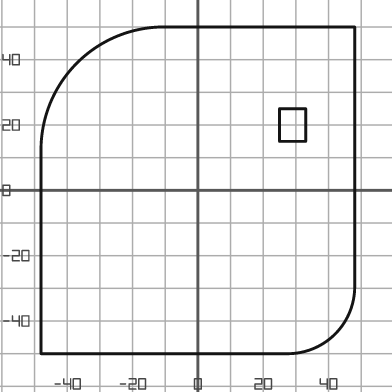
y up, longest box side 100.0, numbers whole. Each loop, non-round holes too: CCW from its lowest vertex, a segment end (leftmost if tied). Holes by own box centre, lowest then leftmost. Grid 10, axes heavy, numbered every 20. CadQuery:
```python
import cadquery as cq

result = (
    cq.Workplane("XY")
    .moveTo(-48.0, -50.0)
    .lineTo(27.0, -50.0)
    .threePointArc((42.0, -44.0), (48.0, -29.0))
    .lineTo(48.0, 50.0)
    .lineTo(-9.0, 50.0)
    .threePointArc((-37.0, 39.0), (-48.0, 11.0))
    .close()
    .moveTo(25.0, 15.0)
    .lineTo(33.0, 15.0)
    .lineTo(33.0, 25.0)
    .lineTo(25.0, 25.0)
    .close()
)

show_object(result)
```